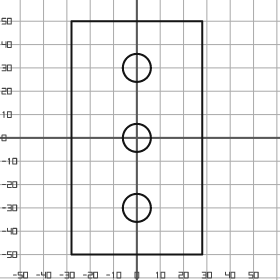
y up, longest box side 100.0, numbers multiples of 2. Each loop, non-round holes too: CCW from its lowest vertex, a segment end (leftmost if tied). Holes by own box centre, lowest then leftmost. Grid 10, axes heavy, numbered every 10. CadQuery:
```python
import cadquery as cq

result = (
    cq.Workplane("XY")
    .moveTo(-28.0, -50.0)
    .lineTo(28.0, -50.0)
    .lineTo(28.0, 50.0)
    .lineTo(-28.0, 50.0)
    .close()
    .moveTo(0.0, -30.0)
    .circle(6.0)
    .moveTo(0.0, 0.0)
    .circle(6.0)
    .moveTo(0.0, 30.0)
    .circle(6.0)
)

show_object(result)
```